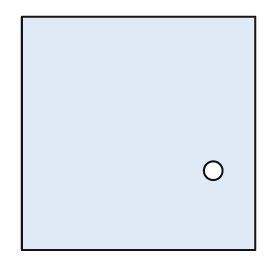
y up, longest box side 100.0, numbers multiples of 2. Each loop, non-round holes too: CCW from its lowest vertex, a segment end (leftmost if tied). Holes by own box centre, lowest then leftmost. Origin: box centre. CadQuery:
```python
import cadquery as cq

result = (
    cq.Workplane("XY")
    .moveTo(-50.0, -50.0)
    .lineTo(50.0, -50.0)
    .lineTo(50.0, 50.0)
    .lineTo(-50.0, 50.0)
    .close()
    .moveTo(32.0, -16.0)
    .circle(4.0)
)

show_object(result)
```